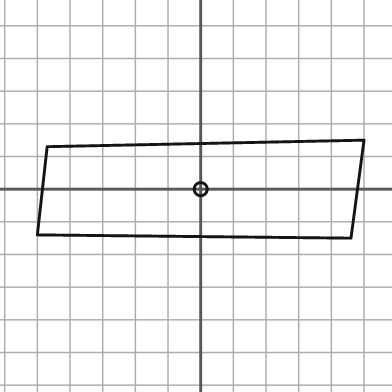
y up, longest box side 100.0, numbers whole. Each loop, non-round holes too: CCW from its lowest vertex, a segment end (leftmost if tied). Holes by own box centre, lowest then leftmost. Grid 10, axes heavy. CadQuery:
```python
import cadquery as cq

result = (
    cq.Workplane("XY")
    .moveTo(46.0, -15.0)
    .lineTo(50.0, 15.0)
    .lineTo(-47.0, 13.0)
    .lineTo(-50.0, -14.0)
    .close()
    .moveTo(0.0, 0.0)
    .circle(2.0)
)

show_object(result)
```